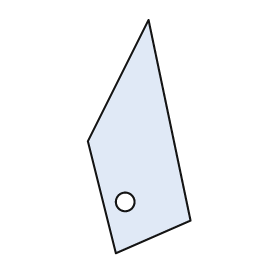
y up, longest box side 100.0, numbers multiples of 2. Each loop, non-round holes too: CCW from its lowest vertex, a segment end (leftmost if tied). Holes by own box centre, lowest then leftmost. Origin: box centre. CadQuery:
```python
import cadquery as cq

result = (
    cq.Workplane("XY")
    .moveTo(-10.0, -50.0)
    .lineTo(22.0, -36.0)
    .lineTo(4.0, 50.0)
    .lineTo(-22.0, -2.0)
    .close()
    .moveTo(-6.0, -28.0)
    .circle(4.0)
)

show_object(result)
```